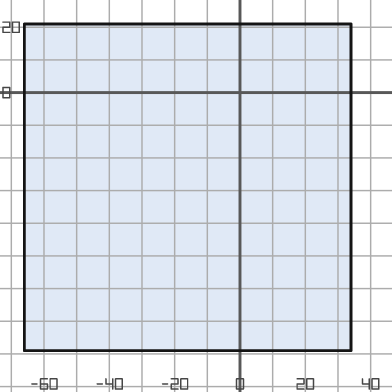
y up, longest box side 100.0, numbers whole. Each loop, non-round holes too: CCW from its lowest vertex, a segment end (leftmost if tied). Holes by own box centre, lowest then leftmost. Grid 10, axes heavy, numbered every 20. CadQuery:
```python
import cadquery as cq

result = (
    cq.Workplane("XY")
    .moveTo(-66.0, -79.0)
    .lineTo(34.0, -79.0)
    .lineTo(34.0, 21.0)
    .lineTo(-66.0, 21.0)
    .close()
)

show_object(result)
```